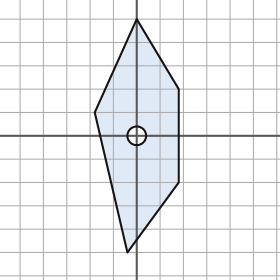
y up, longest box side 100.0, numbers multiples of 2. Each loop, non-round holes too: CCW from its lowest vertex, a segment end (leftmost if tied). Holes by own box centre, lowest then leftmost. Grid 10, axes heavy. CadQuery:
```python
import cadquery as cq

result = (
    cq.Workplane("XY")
    .moveTo(-4.0, -50.0)
    .lineTo(18.0, -20.0)
    .lineTo(18.0, 20.0)
    .lineTo(0.0, 50.0)
    .lineTo(-18.0, 10.0)
    .close()
    .moveTo(0.0, 0.0)
    .circle(4.0)
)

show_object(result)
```